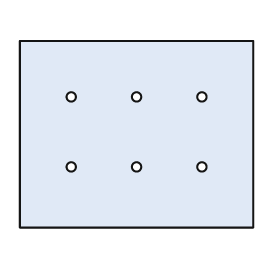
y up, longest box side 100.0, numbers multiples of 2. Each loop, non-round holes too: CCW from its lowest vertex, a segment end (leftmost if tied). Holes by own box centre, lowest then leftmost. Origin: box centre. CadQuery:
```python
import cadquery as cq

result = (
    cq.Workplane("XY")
    .moveTo(-50.0, -40.0)
    .lineTo(50.0, -40.0)
    .lineTo(50.0, 40.0)
    .lineTo(-50.0, 40.0)
    .close()
    .moveTo(-28.0, -14.0)
    .circle(2.0)
    .moveTo(0.0, -14.0)
    .circle(2.0)
    .moveTo(28.0, -14.0)
    .circle(2.0)
    .moveTo(-28.0, 16.0)
    .circle(2.0)
    .moveTo(0.0, 16.0)
    .circle(2.0)
    .moveTo(28.0, 16.0)
    .circle(2.0)
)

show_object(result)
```